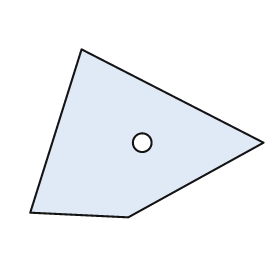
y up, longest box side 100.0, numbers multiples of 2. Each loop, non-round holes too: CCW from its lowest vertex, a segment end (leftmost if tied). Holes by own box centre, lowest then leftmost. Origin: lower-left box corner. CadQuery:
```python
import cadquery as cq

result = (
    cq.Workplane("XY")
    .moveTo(42.0, 0.0)
    .lineTo(100.0, 32.0)
    .lineTo(22.0, 72.0)
    .lineTo(0.0, 2.0)
    .close()
    .moveTo(48.0, 32.0)
    .circle(4.0)
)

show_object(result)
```